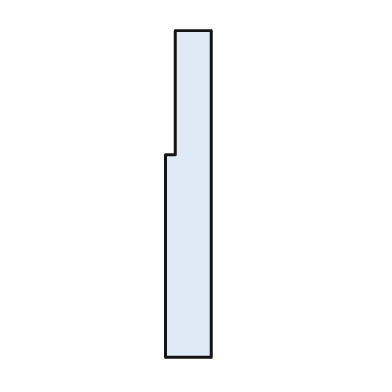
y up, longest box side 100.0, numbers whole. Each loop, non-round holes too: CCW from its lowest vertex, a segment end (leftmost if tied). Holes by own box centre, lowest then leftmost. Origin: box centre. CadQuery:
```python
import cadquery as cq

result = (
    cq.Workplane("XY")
    .moveTo(-7.0, -50.0)
    .lineTo(7.0, -50.0)
    .lineTo(7.0, 50.0)
    .lineTo(-4.0, 50.0)
    .lineTo(-4.0, 12.0)
    .lineTo(-7.0, 12.0)
    .close()
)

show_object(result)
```